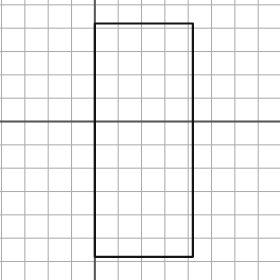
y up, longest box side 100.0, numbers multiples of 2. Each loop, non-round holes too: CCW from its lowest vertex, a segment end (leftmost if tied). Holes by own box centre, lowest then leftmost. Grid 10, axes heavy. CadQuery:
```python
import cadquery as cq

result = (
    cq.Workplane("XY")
    .moveTo(0.0, -58.0)
    .lineTo(42.0, -58.0)
    .lineTo(42.0, 42.0)
    .lineTo(0.0, 42.0)
    .close()
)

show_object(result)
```